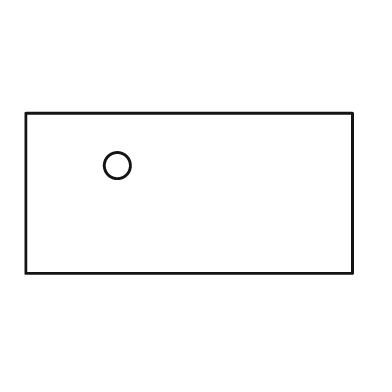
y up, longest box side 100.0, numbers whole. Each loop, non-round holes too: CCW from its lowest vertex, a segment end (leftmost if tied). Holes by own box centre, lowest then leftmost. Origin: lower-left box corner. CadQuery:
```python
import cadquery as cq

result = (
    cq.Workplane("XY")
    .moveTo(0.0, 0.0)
    .lineTo(100.0, 0.0)
    .lineTo(100.0, 49.0)
    .lineTo(0.0, 49.0)
    .close()
    .moveTo(28.0, 33.0)
    .circle(4.0)
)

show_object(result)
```